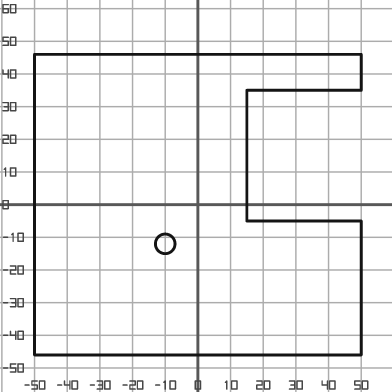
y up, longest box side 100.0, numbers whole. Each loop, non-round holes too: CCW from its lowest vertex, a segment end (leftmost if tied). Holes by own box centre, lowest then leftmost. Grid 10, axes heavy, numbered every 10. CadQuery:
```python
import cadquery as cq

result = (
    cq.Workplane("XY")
    .moveTo(-50.0, -46.0)
    .lineTo(50.0, -46.0)
    .lineTo(50.0, -5.0)
    .lineTo(15.0, -5.0)
    .lineTo(15.0, 35.0)
    .lineTo(50.0, 35.0)
    .lineTo(50.0, 46.0)
    .lineTo(-50.0, 46.0)
    .close()
    .moveTo(-10.0, -12.0)
    .circle(3.0)
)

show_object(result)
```